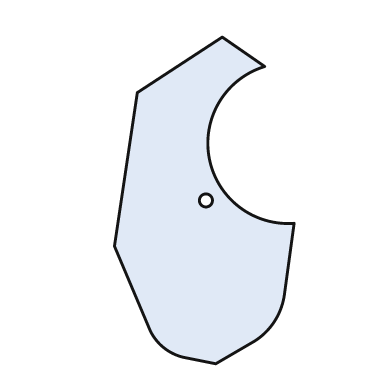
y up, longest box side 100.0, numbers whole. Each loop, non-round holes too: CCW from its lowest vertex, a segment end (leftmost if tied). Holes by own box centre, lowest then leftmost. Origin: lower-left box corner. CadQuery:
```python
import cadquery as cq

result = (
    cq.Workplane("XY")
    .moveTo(31.0, 0.0)
    .lineTo(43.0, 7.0)
    .threePointArc((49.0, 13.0), (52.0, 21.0))
    .lineTo(55.0, 43.0)
    .threePointArc((29.0, 63.0), (46.0, 91.0))
    .lineTo(33.0, 100.0)
    .lineTo(7.0, 83.0)
    .lineTo(0.0, 36.0)
    .lineTo(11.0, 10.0)
    .threePointArc((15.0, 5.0), (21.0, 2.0))
    .close()
    .moveTo(28.0, 50.0)
    .circle(2.0)
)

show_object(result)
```